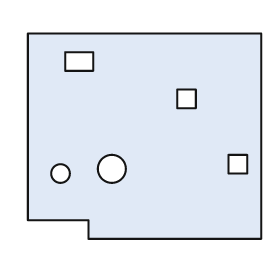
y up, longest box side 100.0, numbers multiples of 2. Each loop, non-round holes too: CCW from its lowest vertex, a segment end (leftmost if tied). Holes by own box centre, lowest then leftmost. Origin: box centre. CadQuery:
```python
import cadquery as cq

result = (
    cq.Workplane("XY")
    .moveTo(-24.0, -44.0)
    .lineTo(50.0, -44.0)
    .lineTo(50.0, 44.0)
    .lineTo(-50.0, 44.0)
    .lineTo(-50.0, -36.0)
    .lineTo(-24.0, -36.0)
    .close()
    .moveTo(-36.0, -16.0)
    .circle(4.0)
    .moveTo(-14.0, -14.0)
    .circle(6.0)
    .moveTo(36.0, -16.0)
    .lineTo(44.0, -16.0)
    .lineTo(44.0, -8.0)
    .lineTo(36.0, -8.0)
    .close()
    .moveTo(14.0, 12.0)
    .lineTo(22.0, 12.0)
    .lineTo(22.0, 20.0)
    .lineTo(14.0, 20.0)
    .close()
    .moveTo(-34.0, 28.0)
    .lineTo(-22.0, 28.0)
    .lineTo(-22.0, 36.0)
    .lineTo(-34.0, 36.0)
    .close()
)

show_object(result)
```